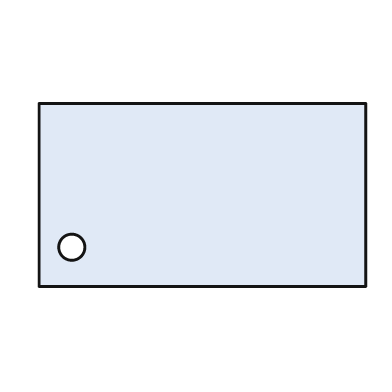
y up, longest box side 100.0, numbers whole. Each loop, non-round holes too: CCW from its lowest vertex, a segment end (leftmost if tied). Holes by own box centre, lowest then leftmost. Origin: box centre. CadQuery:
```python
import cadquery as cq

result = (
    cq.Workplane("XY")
    .moveTo(-50.0, -28.0)
    .lineTo(50.0, -28.0)
    .lineTo(50.0, 28.0)
    .lineTo(-50.0, 28.0)
    .close()
    .moveTo(-40.0, -16.0)
    .circle(4.0)
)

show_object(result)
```